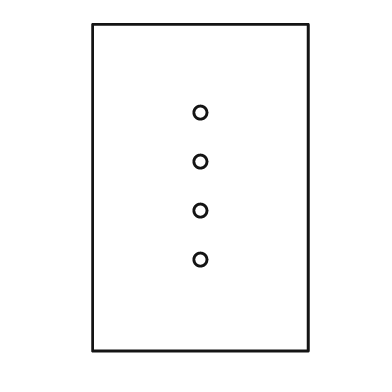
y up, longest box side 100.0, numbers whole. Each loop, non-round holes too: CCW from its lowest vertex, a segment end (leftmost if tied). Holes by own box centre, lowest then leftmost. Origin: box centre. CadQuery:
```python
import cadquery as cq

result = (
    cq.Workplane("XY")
    .moveTo(-33.0, -50.0)
    .lineTo(33.0, -50.0)
    .lineTo(33.0, 50.0)
    .lineTo(-33.0, 50.0)
    .close()
    .moveTo(0.0, -22.0)
    .circle(2.0)
    .moveTo(0.0, -7.0)
    .circle(2.0)
    .moveTo(0.0, 8.0)
    .circle(2.0)
    .moveTo(0.0, 23.0)
    .circle(2.0)
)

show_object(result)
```